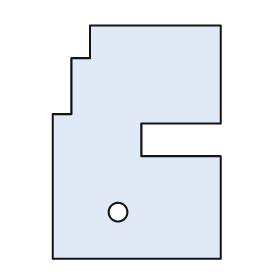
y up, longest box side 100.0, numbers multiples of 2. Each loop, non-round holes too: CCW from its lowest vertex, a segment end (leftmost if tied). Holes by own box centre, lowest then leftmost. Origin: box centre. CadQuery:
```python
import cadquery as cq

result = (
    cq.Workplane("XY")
    .moveTo(-36.0, -50.0)
    .lineTo(36.0, -50.0)
    .lineTo(36.0, -6.0)
    .lineTo(2.0, -6.0)
    .lineTo(2.0, 8.0)
    .lineTo(36.0, 8.0)
    .lineTo(36.0, 50.0)
    .lineTo(-20.0, 50.0)
    .lineTo(-20.0, 36.0)
    .lineTo(-28.0, 36.0)
    .lineTo(-28.0, 12.0)
    .lineTo(-36.0, 12.0)
    .close()
    .moveTo(-8.0, -30.0)
    .circle(4.0)
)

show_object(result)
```